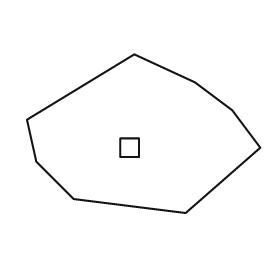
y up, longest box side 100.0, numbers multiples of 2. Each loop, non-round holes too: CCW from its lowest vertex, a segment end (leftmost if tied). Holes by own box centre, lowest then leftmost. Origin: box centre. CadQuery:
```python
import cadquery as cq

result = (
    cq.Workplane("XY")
    .moveTo(18.0, -34.0)
    .lineTo(50.0, -6.0)
    .lineTo(38.0, 10.0)
    .lineTo(22.0, 22.0)
    .lineTo(-4.0, 34.0)
    .lineTo(-50.0, 6.0)
    .lineTo(-46.0, -12.0)
    .lineTo(-30.0, -28.0)
    .close()
    .moveTo(-10.0, -10.0)
    .lineTo(-2.0, -10.0)
    .lineTo(-2.0, -2.0)
    .lineTo(-10.0, -2.0)
    .close()
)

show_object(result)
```